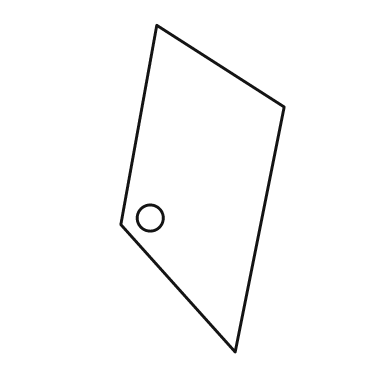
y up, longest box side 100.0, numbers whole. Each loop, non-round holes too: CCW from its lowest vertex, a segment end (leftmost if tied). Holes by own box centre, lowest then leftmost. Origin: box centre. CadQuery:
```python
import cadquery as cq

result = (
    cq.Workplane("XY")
    .moveTo(10.0, -50.0)
    .lineTo(25.0, 25.0)
    .lineTo(-14.0, 50.0)
    .lineTo(-25.0, -11.0)
    .close()
    .moveTo(-16.0, -9.0)
    .circle(4.0)
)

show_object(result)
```